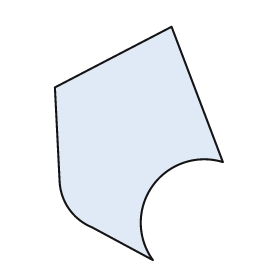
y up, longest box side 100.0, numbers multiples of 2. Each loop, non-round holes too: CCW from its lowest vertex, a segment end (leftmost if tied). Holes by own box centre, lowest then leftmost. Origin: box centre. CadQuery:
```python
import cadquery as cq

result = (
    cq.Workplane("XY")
    .moveTo(6.0, -50.0)
    .threePointArc((6.0, -18.0), (36.0, -8.0))
    .lineTo(14.0, 50.0)
    .lineTo(-36.0, 24.0)
    .lineTo(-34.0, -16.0)
    .threePointArc((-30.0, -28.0), (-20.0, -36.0))
    .close()
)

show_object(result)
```